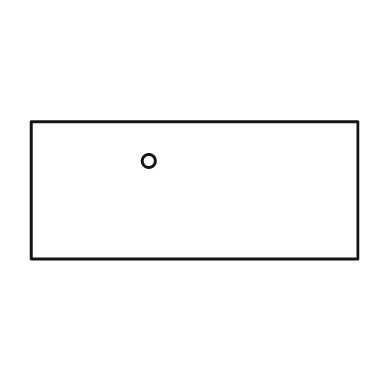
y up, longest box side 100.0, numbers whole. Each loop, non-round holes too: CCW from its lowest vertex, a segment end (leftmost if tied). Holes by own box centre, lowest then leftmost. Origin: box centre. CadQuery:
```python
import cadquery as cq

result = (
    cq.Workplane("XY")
    .moveTo(-50.0, -21.0)
    .lineTo(50.0, -21.0)
    .lineTo(50.0, 21.0)
    .lineTo(-50.0, 21.0)
    .close()
    .moveTo(-14.0, 9.0)
    .circle(2.0)
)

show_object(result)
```